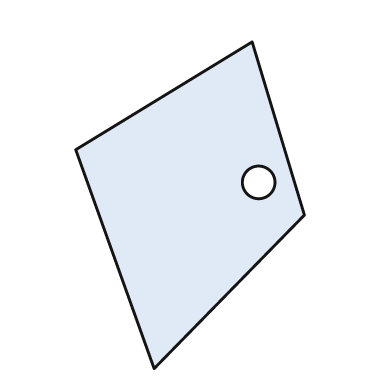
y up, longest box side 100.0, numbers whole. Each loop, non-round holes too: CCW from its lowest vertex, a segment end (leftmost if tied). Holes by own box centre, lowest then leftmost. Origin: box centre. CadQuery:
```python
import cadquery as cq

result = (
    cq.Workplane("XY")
    .moveTo(-11.0, -50.0)
    .lineTo(35.0, -3.0)
    .lineTo(19.0, 50.0)
    .lineTo(-35.0, 17.0)
    .close()
    .moveTo(21.0, 7.0)
    .circle(5.0)
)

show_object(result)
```